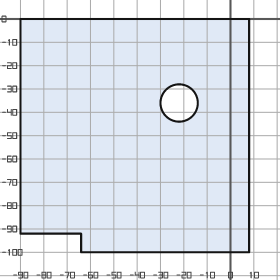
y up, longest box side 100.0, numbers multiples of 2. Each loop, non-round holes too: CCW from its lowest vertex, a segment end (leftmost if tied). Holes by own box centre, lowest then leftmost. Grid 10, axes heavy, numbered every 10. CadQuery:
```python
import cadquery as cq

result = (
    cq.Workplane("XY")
    .moveTo(-64.0, -100.0)
    .lineTo(8.0, -100.0)
    .lineTo(8.0, 0.0)
    .lineTo(-90.0, 0.0)
    .lineTo(-90.0, -92.0)
    .lineTo(-64.0, -92.0)
    .close()
    .moveTo(-22.0, -36.0)
    .circle(8.0)
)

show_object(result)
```